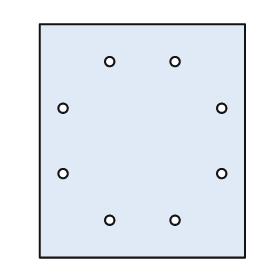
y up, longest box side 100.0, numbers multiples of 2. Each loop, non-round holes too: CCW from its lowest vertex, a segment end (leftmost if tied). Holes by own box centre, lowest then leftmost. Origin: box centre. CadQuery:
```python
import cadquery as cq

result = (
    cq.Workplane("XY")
    .moveTo(-44.0, -50.0)
    .lineTo(44.0, -50.0)
    .lineTo(44.0, 50.0)
    .lineTo(-44.0, 50.0)
    .close()
    .moveTo(-14.0, -34.0)
    .circle(2.0)
    .moveTo(14.0, -34.0)
    .circle(2.0)
    .moveTo(-34.0, -14.0)
    .circle(2.0)
    .moveTo(34.0, -14.0)
    .circle(2.0)
    .moveTo(-34.0, 14.0)
    .circle(2.0)
    .moveTo(34.0, 14.0)
    .circle(2.0)
    .moveTo(-14.0, 34.0)
    .circle(2.0)
    .moveTo(14.0, 34.0)
    .circle(2.0)
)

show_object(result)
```